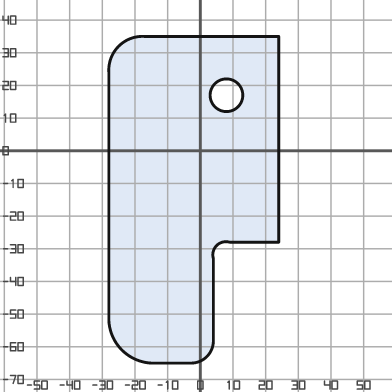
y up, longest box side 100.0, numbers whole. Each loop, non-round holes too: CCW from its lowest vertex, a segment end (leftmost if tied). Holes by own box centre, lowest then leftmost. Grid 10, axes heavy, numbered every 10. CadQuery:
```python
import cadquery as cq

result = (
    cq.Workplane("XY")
    .moveTo(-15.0, -65.0)
    .lineTo(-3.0, -65.0)
    .threePointArc((2.0, -63.0), (4.0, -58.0))
    .lineTo(4.0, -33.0)
    .threePointArc((5.0, -29.0), (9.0, -28.0))
    .lineTo(24.0, -28.0)
    .lineTo(24.0, 35.0)
    .lineTo(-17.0, 35.0)
    .threePointArc((-25.0, 32.0), (-28.0, 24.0))
    .lineTo(-28.0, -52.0)
    .threePointArc((-24.0, -61.0), (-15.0, -65.0))
    .close()
    .moveTo(8.0, 17.0)
    .circle(5.0)
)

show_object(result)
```